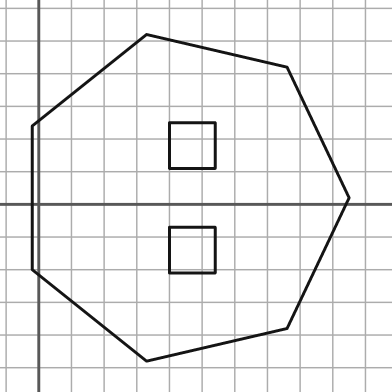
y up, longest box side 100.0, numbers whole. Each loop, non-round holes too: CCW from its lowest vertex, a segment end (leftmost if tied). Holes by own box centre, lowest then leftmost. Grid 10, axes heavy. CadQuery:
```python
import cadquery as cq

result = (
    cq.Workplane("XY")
    .moveTo(33.0, -48.0)
    .lineTo(76.0, -38.0)
    .lineTo(95.0, 2.0)
    .lineTo(76.0, 42.0)
    .lineTo(33.0, 52.0)
    .lineTo(-2.0, 24.0)
    .lineTo(-2.0, -20.0)
    .close()
    .moveTo(40.0, -21.0)
    .lineTo(54.0, -21.0)
    .lineTo(54.0, -7.0)
    .lineTo(40.0, -7.0)
    .close()
    .moveTo(40.0, 11.0)
    .lineTo(54.0, 11.0)
    .lineTo(54.0, 25.0)
    .lineTo(40.0, 25.0)
    .close()
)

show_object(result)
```